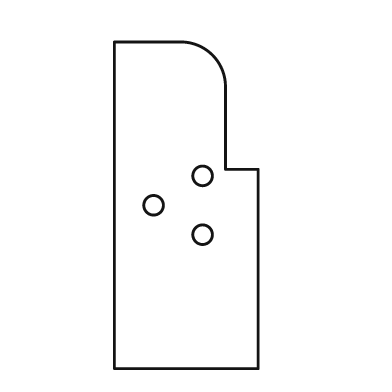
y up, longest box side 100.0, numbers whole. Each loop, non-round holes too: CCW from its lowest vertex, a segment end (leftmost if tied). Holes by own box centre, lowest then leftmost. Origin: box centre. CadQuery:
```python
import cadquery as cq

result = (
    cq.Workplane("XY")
    .moveTo(-22.0, -50.0)
    .lineTo(22.0, -50.0)
    .lineTo(22.0, 11.0)
    .lineTo(12.0, 11.0)
    .lineTo(12.0, 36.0)
    .threePointArc((8.0, 46.0), (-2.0, 50.0))
    .lineTo(-22.0, 50.0)
    .close()
    .moveTo(5.0, -9.0)
    .circle(3.0)
    .moveTo(-10.0, 0.0)
    .circle(3.0)
    .moveTo(5.0, 9.0)
    .circle(3.0)
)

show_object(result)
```